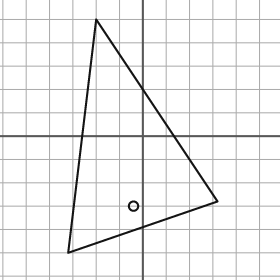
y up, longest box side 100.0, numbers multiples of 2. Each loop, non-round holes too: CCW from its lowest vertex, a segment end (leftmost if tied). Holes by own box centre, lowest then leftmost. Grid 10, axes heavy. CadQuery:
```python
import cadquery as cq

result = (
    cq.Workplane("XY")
    .moveTo(-32.0, -50.0)
    .lineTo(32.0, -28.0)
    .lineTo(-20.0, 50.0)
    .close()
    .moveTo(-4.0, -30.0)
    .circle(2.0)
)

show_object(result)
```